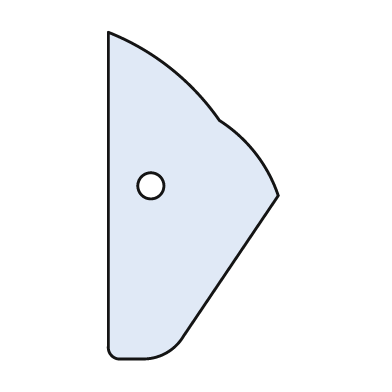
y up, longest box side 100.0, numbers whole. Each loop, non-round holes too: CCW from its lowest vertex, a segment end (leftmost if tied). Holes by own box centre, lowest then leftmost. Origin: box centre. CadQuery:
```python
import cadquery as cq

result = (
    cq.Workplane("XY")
    .moveTo(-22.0, -50.0)
    .lineTo(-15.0, -50.0)
    .threePointArc((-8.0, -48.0), (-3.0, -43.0))
    .lineTo(26.0, 0.0)
    .threePointArc((19.0, 13.0), (8.0, 23.0))
    .threePointArc((-7.0, 39.0), (-26.0, 50.0))
    .lineTo(-26.0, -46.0)
    .threePointArc((-25.0, -49.0), (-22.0, -50.0))
    .close()
    .moveTo(-13.0, 3.0)
    .circle(4.0)
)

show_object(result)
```